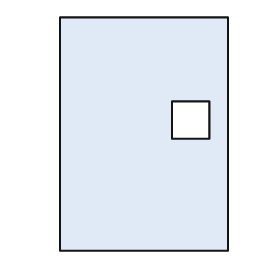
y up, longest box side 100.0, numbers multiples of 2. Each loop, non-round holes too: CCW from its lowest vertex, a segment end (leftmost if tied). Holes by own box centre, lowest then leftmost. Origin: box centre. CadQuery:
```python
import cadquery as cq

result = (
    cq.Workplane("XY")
    .moveTo(-36.0, -50.0)
    .lineTo(36.0, -50.0)
    .lineTo(36.0, 50.0)
    .lineTo(-36.0, 50.0)
    .close()
    .moveTo(12.0, -2.0)
    .lineTo(28.0, -2.0)
    .lineTo(28.0, 14.0)
    .lineTo(12.0, 14.0)
    .close()
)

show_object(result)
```